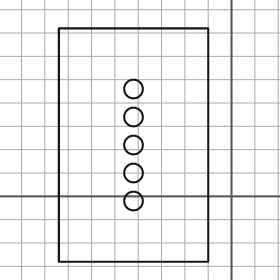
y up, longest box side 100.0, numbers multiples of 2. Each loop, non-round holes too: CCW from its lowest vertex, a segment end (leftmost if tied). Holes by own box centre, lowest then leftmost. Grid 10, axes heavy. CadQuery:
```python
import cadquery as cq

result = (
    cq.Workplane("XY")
    .moveTo(-74.0, -28.0)
    .lineTo(-10.0, -28.0)
    .lineTo(-10.0, 72.0)
    .lineTo(-74.0, 72.0)
    .close()
    .moveTo(-42.0, -2.0)
    .circle(4.0)
    .moveTo(-42.0, 10.0)
    .circle(4.0)
    .moveTo(-42.0, 22.0)
    .circle(4.0)
    .moveTo(-42.0, 34.0)
    .circle(4.0)
    .moveTo(-42.0, 46.0)
    .circle(4.0)
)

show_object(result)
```